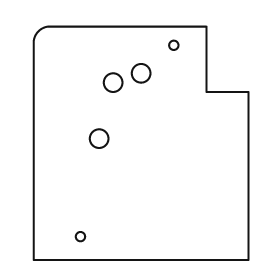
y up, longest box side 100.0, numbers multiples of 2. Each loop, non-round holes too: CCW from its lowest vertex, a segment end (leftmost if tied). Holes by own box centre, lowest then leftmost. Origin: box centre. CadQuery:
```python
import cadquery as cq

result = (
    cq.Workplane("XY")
    .moveTo(-46.0, -50.0)
    .lineTo(46.0, -50.0)
    .lineTo(46.0, 22.0)
    .lineTo(28.0, 22.0)
    .lineTo(28.0, 50.0)
    .lineTo(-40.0, 50.0)
    .threePointArc((-44.0, 48.0), (-46.0, 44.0))
    .close()
    .moveTo(-26.0, -40.0)
    .circle(2.0)
    .moveTo(-18.0, 2.0)
    .circle(4.0)
    .moveTo(-12.0, 26.0)
    .circle(4.0)
    .moveTo(0.0, 30.0)
    .circle(4.0)
    .moveTo(14.0, 42.0)
    .circle(2.0)
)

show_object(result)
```